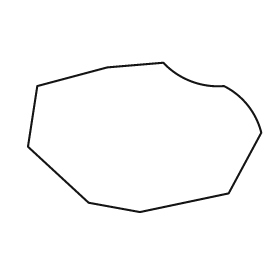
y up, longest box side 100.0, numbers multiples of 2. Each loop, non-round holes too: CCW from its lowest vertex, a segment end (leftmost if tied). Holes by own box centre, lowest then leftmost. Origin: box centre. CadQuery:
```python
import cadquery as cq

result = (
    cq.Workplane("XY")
    .moveTo(-2.0, -32.0)
    .lineTo(36.0, -24.0)
    .lineTo(50.0, 2.0)
    .threePointArc((44.0, 14.0), (34.0, 22.0))
    .threePointArc((20.0, 24.0), (8.0, 32.0))
    .lineTo(-16.0, 30.0)
    .lineTo(-46.0, 22.0)
    .lineTo(-50.0, -4.0)
    .lineTo(-24.0, -28.0)
    .close()
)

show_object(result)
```